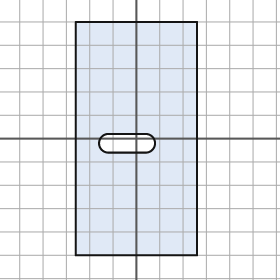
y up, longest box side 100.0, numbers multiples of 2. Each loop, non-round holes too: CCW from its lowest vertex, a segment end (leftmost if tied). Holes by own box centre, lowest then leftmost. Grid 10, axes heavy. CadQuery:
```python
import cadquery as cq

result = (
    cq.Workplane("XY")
    .moveTo(-26.0, -50.0)
    .lineTo(26.0, -50.0)
    .lineTo(26.0, 50.0)
    .lineTo(-26.0, 50.0)
    .close()
    .moveTo(-12.0, -6.0)
    .lineTo(4.0, -6.0)
    .threePointArc((8.0, -2.0), (4.0, 2.0))
    .lineTo(-12.0, 2.0)
    .threePointArc((-16.0, -2.0), (-12.0, -6.0))
    .close()
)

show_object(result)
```